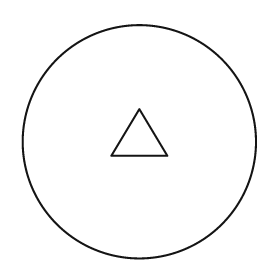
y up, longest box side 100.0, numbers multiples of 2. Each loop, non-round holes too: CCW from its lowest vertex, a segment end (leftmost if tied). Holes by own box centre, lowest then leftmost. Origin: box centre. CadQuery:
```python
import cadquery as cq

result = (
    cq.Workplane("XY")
    .moveTo(0.0, 0.0)
    .circle(50.0)
    .moveTo(-12.0, -6.0)
    .lineTo(12.0, -6.0)
    .lineTo(0.0, 14.0)
    .close()
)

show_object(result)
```